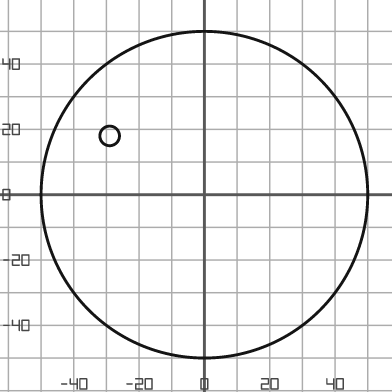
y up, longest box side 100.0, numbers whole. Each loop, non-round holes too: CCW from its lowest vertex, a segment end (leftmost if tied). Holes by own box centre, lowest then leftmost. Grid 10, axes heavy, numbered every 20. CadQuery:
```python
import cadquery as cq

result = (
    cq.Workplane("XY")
    .moveTo(0.0, 0.0)
    .circle(50.0)
    .moveTo(-29.0, 18.0)
    .circle(3.0)
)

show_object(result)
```